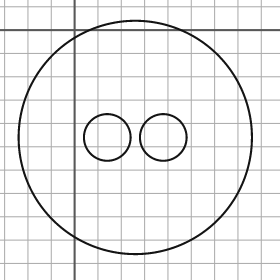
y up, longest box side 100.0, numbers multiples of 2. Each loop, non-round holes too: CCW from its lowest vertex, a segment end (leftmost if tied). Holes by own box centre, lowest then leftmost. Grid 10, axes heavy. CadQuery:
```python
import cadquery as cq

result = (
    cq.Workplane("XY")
    .moveTo(26.0, -46.0)
    .circle(50.0)
    .moveTo(14.0, -46.0)
    .circle(10.0)
    .moveTo(38.0, -46.0)
    .circle(10.0)
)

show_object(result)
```